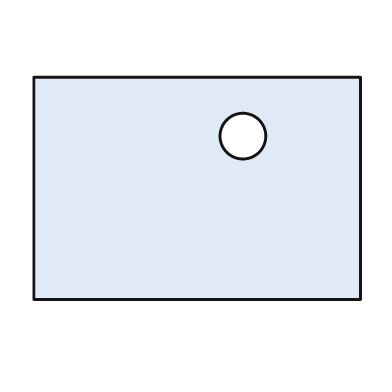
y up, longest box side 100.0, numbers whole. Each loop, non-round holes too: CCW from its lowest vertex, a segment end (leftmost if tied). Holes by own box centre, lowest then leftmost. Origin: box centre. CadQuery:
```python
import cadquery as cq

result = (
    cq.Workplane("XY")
    .moveTo(-50.0, -34.0)
    .lineTo(50.0, -34.0)
    .lineTo(50.0, 34.0)
    .lineTo(-50.0, 34.0)
    .close()
    .moveTo(14.0, 16.0)
    .circle(7.0)
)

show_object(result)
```